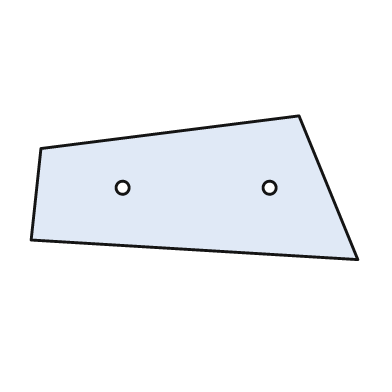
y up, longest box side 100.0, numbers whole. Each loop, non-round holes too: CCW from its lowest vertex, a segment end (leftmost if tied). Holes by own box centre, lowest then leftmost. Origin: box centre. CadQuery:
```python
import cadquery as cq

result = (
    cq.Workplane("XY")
    .moveTo(50.0, -22.0)
    .lineTo(32.0, 22.0)
    .lineTo(-47.0, 12.0)
    .lineTo(-50.0, -16.0)
    .close()
    .moveTo(-22.0, 0.0)
    .circle(2.0)
    .moveTo(23.0, 0.0)
    .circle(2.0)
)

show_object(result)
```